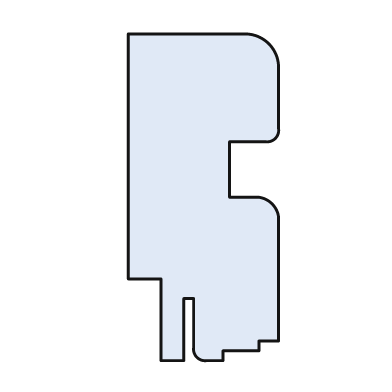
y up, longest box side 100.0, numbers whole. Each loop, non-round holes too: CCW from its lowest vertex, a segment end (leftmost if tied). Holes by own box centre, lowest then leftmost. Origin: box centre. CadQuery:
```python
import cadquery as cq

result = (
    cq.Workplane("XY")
    .moveTo(-13.0, -50.0)
    .lineTo(-6.0, -50.0)
    .lineTo(-6.0, -31.0)
    .lineTo(-3.0, -31.0)
    .lineTo(-3.0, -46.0)
    .threePointArc((-2.0, -49.0), (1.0, -50.0))
    .lineTo(6.0, -50.0)
    .lineTo(6.0, -47.0)
    .lineTo(17.0, -47.0)
    .lineTo(17.0, -44.0)
    .lineTo(23.0, -44.0)
    .lineTo(23.0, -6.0)
    .threePointArc((21.0, -2.0), (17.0, 0.0))
    .lineTo(8.0, 0.0)
    .lineTo(8.0, 17.0)
    .lineTo(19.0, 17.0)
    .threePointArc((22.0, 18.0), (23.0, 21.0))
    .lineTo(23.0, 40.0)
    .threePointArc((20.0, 47.0), (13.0, 50.0))
    .lineTo(-23.0, 50.0)
    .lineTo(-23.0, -25.0)
    .lineTo(-13.0, -25.0)
    .close()
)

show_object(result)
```